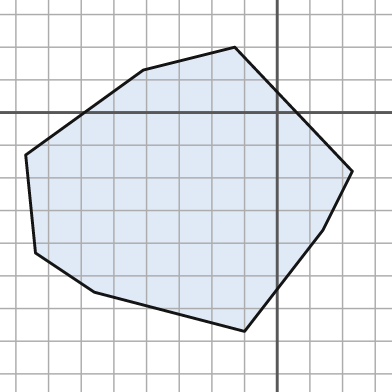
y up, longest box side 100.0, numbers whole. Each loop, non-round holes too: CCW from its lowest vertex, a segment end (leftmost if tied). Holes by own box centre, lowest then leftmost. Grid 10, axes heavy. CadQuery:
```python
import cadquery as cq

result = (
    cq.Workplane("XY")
    .moveTo(-10.0, -67.0)
    .lineTo(14.0, -36.0)
    .lineTo(23.0, -18.0)
    .lineTo(-13.0, 20.0)
    .lineTo(-41.0, 13.0)
    .lineTo(-77.0, -13.0)
    .lineTo(-74.0, -43.0)
    .lineTo(-56.0, -55.0)
    .close()
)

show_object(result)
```